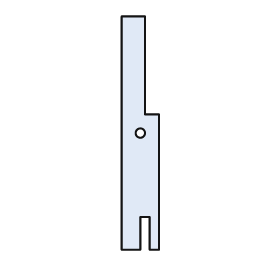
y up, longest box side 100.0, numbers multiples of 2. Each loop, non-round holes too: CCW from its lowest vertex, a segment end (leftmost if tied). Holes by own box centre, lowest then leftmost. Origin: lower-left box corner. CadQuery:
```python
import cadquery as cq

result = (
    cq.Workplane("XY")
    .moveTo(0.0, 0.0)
    .lineTo(8.0, 0.0)
    .lineTo(8.0, 14.0)
    .lineTo(12.0, 14.0)
    .lineTo(12.0, 0.0)
    .lineTo(16.0, 0.0)
    .lineTo(16.0, 58.0)
    .lineTo(10.0, 58.0)
    .lineTo(10.0, 100.0)
    .lineTo(0.0, 100.0)
    .close()
    .moveTo(8.0, 50.0)
    .circle(2.0)
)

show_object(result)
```